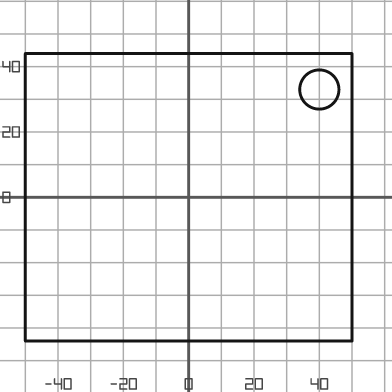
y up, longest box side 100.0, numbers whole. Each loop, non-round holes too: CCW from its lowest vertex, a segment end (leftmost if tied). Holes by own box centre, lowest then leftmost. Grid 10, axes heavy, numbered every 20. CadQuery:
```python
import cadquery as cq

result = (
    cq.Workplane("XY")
    .moveTo(-50.0, -44.0)
    .lineTo(50.0, -44.0)
    .lineTo(50.0, 44.0)
    .lineTo(-50.0, 44.0)
    .close()
    .moveTo(40.0, 33.0)
    .circle(6.0)
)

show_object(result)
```